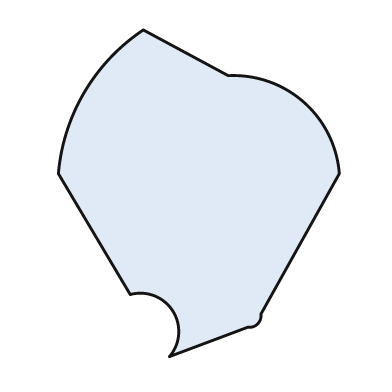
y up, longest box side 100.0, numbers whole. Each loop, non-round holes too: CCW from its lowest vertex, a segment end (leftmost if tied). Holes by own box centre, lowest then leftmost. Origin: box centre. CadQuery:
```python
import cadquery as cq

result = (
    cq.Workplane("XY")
    .moveTo(-9.0, -50.0)
    .lineTo(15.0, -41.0)
    .threePointArc((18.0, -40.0), (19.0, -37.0))
    .lineTo(43.0, 6.0)
    .threePointArc((32.0, 28.0), (9.0, 36.0))
    .lineTo(-17.0, 50.0)
    .threePointArc((-35.0, 31.0), (-43.0, 6.0))
    .lineTo(-21.0, -31.0)
    .threePointArc((-8.0, -36.0), (-9.0, -50.0))
    .close()
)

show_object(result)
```